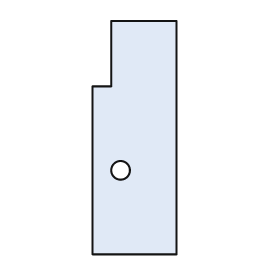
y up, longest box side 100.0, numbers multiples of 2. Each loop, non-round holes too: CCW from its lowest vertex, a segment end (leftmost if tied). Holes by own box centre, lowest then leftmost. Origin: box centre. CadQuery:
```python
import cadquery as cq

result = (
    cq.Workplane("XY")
    .moveTo(-18.0, -50.0)
    .lineTo(18.0, -50.0)
    .lineTo(18.0, 50.0)
    .lineTo(-10.0, 50.0)
    .lineTo(-10.0, 22.0)
    .lineTo(-18.0, 22.0)
    .close()
    .moveTo(-6.0, -14.0)
    .circle(4.0)
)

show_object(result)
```